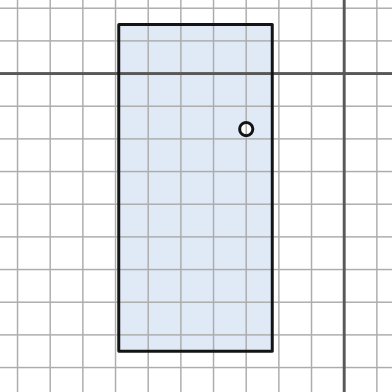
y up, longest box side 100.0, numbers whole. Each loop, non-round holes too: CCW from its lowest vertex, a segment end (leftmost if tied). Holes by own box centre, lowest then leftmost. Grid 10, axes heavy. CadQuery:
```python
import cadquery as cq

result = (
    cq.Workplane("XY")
    .moveTo(-69.0, -85.0)
    .lineTo(-22.0, -85.0)
    .lineTo(-22.0, 15.0)
    .lineTo(-69.0, 15.0)
    .close()
    .moveTo(-30.0, -17.0)
    .circle(2.0)
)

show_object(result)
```